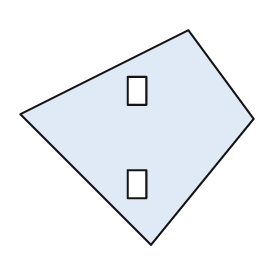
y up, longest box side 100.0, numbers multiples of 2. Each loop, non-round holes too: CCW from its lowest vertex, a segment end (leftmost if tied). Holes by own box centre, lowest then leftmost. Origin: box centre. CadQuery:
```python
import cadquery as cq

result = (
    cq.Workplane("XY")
    .moveTo(6.0, -46.0)
    .lineTo(50.0, 8.0)
    .lineTo(22.0, 46.0)
    .lineTo(-50.0, 10.0)
    .close()
    .moveTo(-4.0, -26.0)
    .lineTo(4.0, -26.0)
    .lineTo(4.0, -14.0)
    .lineTo(-4.0, -14.0)
    .close()
    .moveTo(-4.0, 14.0)
    .lineTo(4.0, 14.0)
    .lineTo(4.0, 26.0)
    .lineTo(-4.0, 26.0)
    .close()
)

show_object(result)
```